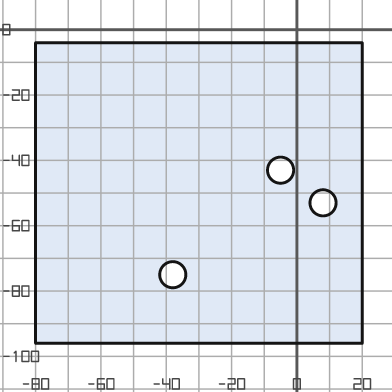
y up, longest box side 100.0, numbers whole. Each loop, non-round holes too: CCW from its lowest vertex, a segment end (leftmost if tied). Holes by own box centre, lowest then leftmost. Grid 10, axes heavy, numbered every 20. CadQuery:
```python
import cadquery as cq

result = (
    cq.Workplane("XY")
    .moveTo(-80.0, -96.0)
    .lineTo(20.0, -96.0)
    .lineTo(20.0, -4.0)
    .lineTo(-80.0, -4.0)
    .close()
    .moveTo(-38.0, -75.0)
    .circle(4.0)
    .moveTo(8.0, -53.0)
    .circle(4.0)
    .moveTo(-5.0, -43.0)
    .circle(4.0)
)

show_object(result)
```